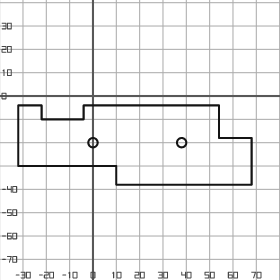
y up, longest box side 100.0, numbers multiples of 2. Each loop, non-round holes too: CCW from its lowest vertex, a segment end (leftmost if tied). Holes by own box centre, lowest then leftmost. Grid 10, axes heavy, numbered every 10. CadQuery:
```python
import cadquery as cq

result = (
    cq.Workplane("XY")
    .moveTo(10.0, -38.0)
    .lineTo(68.0, -38.0)
    .lineTo(68.0, -18.0)
    .lineTo(54.0, -18.0)
    .lineTo(54.0, -4.0)
    .lineTo(-4.0, -4.0)
    .lineTo(-4.0, -10.0)
    .lineTo(-22.0, -10.0)
    .lineTo(-22.0, -4.0)
    .lineTo(-32.0, -4.0)
    .lineTo(-32.0, -30.0)
    .lineTo(10.0, -30.0)
    .close()
    .moveTo(0.0, -20.0)
    .circle(2.0)
    .moveTo(38.0, -20.0)
    .circle(2.0)
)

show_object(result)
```